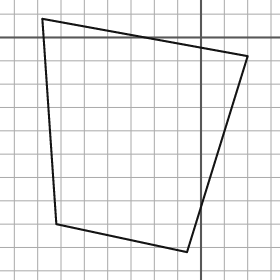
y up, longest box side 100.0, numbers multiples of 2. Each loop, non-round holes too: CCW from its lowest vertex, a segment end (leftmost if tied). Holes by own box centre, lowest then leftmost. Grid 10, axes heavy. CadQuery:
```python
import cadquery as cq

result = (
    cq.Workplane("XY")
    .moveTo(-6.0, -92.0)
    .lineTo(20.0, -8.0)
    .lineTo(-68.0, 8.0)
    .lineTo(-62.0, -80.0)
    .close()
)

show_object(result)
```